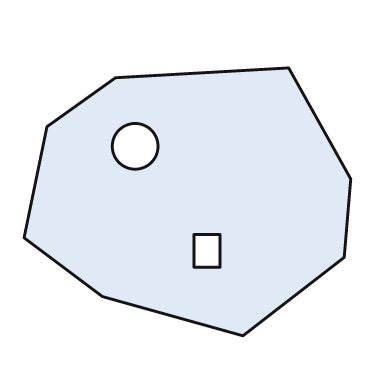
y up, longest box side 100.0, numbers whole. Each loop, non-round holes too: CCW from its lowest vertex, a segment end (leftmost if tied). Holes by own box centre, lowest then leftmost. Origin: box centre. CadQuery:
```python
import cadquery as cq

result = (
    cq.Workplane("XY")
    .moveTo(17.0, -41.0)
    .lineTo(48.0, -17.0)
    .lineTo(50.0, 7.0)
    .lineTo(31.0, 41.0)
    .lineTo(-22.0, 38.0)
    .lineTo(-43.0, 23.0)
    .lineTo(-50.0, -11.0)
    .lineTo(-26.0, -29.0)
    .close()
    .moveTo(2.0, -20.0)
    .lineTo(10.0, -20.0)
    .lineTo(10.0, -10.0)
    .lineTo(2.0, -10.0)
    .close()
    .moveTo(-16.0, 17.0)
    .circle(7.0)
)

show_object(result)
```